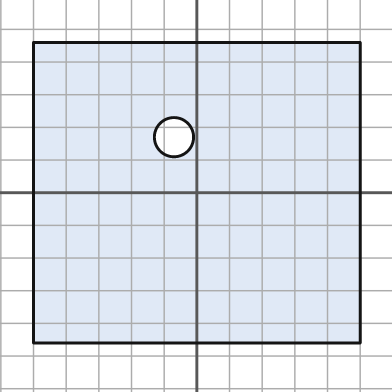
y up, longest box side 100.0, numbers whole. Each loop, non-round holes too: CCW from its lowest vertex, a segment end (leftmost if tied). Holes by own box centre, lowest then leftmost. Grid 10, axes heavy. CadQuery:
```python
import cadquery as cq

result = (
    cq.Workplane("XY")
    .moveTo(-50.0, -46.0)
    .lineTo(50.0, -46.0)
    .lineTo(50.0, 46.0)
    .lineTo(-50.0, 46.0)
    .close()
    .moveTo(-7.0, 17.0)
    .circle(6.0)
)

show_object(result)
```